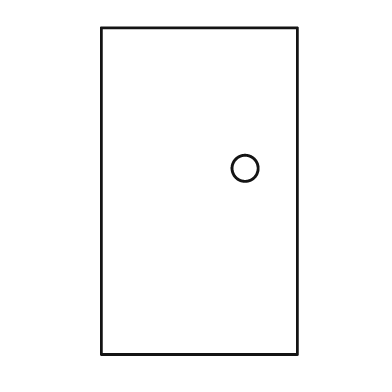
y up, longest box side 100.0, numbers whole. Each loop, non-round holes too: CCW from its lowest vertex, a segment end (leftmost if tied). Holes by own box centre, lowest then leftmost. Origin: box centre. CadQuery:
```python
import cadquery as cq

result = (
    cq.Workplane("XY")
    .moveTo(-30.0, -50.0)
    .lineTo(30.0, -50.0)
    .lineTo(30.0, 50.0)
    .lineTo(-30.0, 50.0)
    .close()
    .moveTo(14.0, 7.0)
    .circle(4.0)
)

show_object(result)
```